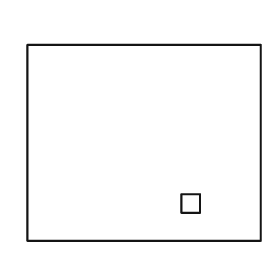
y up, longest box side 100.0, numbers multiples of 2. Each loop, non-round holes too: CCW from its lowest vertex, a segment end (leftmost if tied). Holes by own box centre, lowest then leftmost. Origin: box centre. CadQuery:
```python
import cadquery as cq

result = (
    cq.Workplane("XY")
    .moveTo(-50.0, -42.0)
    .lineTo(50.0, -42.0)
    .lineTo(50.0, 42.0)
    .lineTo(-50.0, 42.0)
    .close()
    .moveTo(16.0, -30.0)
    .lineTo(24.0, -30.0)
    .lineTo(24.0, -22.0)
    .lineTo(16.0, -22.0)
    .close()
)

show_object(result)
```